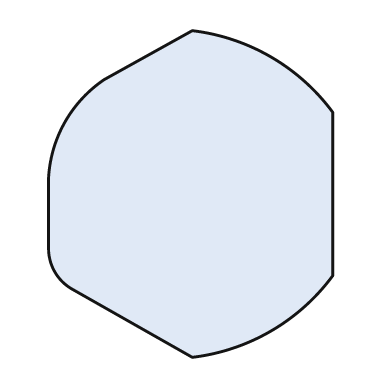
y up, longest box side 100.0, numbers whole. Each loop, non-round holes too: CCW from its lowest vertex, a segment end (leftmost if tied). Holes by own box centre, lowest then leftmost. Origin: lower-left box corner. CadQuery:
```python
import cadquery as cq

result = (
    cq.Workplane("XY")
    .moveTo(44.0, 0.0)
    .threePointArc((68.0, 8.0), (87.0, 25.0))
    .lineTo(87.0, 75.0)
    .threePointArc((68.0, 92.0), (44.0, 100.0))
    .lineTo(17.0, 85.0)
    .threePointArc((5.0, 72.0), (0.0, 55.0))
    .lineTo(0.0, 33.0)
    .threePointArc((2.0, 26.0), (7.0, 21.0))
    .close()
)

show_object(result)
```